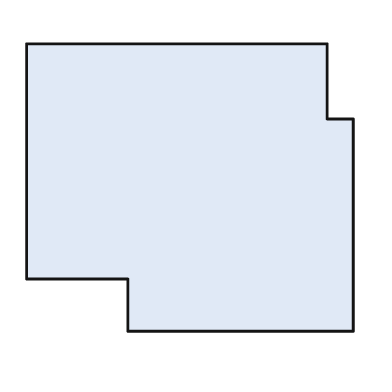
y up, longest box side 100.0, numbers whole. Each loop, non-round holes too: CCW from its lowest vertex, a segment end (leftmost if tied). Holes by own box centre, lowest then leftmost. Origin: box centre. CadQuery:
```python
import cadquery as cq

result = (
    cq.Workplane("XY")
    .moveTo(-19.0, -44.0)
    .lineTo(50.0, -44.0)
    .lineTo(50.0, 21.0)
    .lineTo(42.0, 21.0)
    .lineTo(42.0, 44.0)
    .lineTo(-50.0, 44.0)
    .lineTo(-50.0, -28.0)
    .lineTo(-19.0, -28.0)
    .close()
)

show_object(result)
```